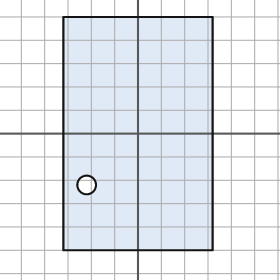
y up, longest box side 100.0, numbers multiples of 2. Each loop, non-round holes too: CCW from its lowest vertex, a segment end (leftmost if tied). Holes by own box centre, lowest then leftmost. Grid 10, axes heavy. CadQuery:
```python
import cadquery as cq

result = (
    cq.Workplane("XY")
    .moveTo(-32.0, -50.0)
    .lineTo(32.0, -50.0)
    .lineTo(32.0, 50.0)
    .lineTo(-32.0, 50.0)
    .close()
    .moveTo(-22.0, -22.0)
    .circle(4.0)
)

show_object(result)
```